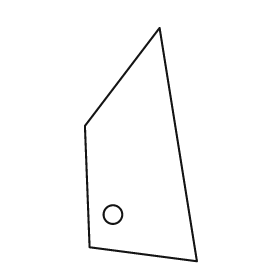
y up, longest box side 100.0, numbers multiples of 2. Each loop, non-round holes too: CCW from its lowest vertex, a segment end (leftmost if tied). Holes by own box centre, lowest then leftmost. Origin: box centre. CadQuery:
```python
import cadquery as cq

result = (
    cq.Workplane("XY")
    .moveTo(24.0, -50.0)
    .lineTo(8.0, 50.0)
    .lineTo(-24.0, 8.0)
    .lineTo(-22.0, -44.0)
    .close()
    .moveTo(-12.0, -30.0)
    .circle(4.0)
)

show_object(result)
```